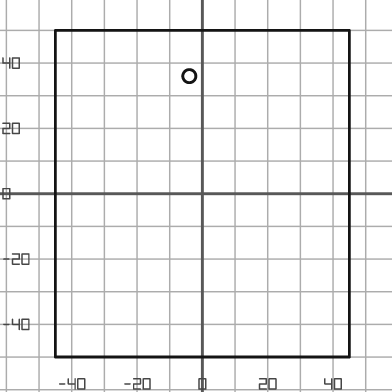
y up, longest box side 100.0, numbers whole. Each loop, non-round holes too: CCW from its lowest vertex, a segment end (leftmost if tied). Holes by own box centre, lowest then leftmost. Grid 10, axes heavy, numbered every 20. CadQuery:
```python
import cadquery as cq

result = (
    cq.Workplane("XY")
    .moveTo(-45.0, -50.0)
    .lineTo(45.0, -50.0)
    .lineTo(45.0, 50.0)
    .lineTo(-45.0, 50.0)
    .close()
    .moveTo(-4.0, 36.0)
    .circle(2.0)
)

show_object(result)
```